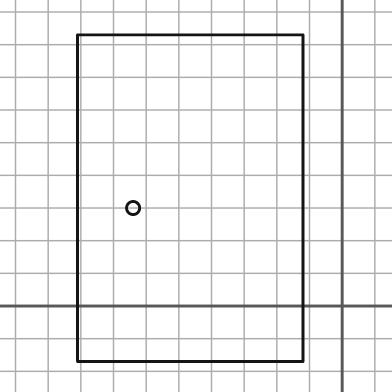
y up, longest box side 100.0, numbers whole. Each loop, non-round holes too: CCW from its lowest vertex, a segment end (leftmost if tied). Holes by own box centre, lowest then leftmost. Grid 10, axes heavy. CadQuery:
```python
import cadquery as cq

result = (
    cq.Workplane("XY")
    .moveTo(-81.0, -17.0)
    .lineTo(-12.0, -17.0)
    .lineTo(-12.0, 83.0)
    .lineTo(-81.0, 83.0)
    .close()
    .moveTo(-64.0, 30.0)
    .circle(2.0)
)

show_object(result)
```